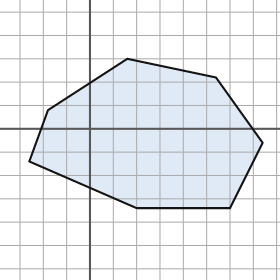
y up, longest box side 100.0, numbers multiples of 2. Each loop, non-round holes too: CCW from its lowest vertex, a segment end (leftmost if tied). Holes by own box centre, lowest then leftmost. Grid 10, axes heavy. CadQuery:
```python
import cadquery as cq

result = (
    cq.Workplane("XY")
    .moveTo(20.0, -34.0)
    .lineTo(60.0, -34.0)
    .lineTo(74.0, -6.0)
    .lineTo(54.0, 22.0)
    .lineTo(16.0, 30.0)
    .lineTo(-18.0, 8.0)
    .lineTo(-26.0, -14.0)
    .close()
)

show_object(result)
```